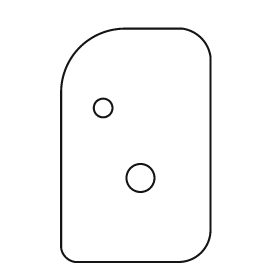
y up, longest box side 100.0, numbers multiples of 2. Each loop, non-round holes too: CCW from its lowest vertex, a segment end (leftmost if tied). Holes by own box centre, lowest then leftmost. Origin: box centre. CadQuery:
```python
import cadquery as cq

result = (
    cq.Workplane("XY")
    .moveTo(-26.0, -50.0)
    .lineTo(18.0, -50.0)
    .threePointArc((28.0, -46.0), (32.0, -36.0))
    .lineTo(32.0, 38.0)
    .threePointArc((28.0, 46.0), (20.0, 50.0))
    .lineTo(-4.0, 50.0)
    .threePointArc((-24.0, 42.0), (-32.0, 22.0))
    .lineTo(-32.0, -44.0)
    .threePointArc((-30.0, -48.0), (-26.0, -50.0))
    .close()
    .moveTo(2.0, -14.0)
    .circle(6.0)
    .moveTo(-14.0, 16.0)
    .circle(4.0)
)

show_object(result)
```